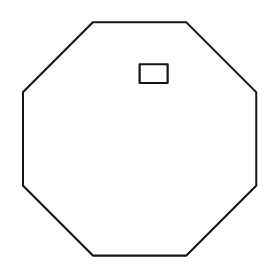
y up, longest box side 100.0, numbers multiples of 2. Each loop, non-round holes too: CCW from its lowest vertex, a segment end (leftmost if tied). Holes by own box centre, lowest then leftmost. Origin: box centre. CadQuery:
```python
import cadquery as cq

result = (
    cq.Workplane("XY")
    .moveTo(-20.0, -50.0)
    .lineTo(20.0, -50.0)
    .lineTo(50.0, -20.0)
    .lineTo(50.0, 20.0)
    .lineTo(20.0, 50.0)
    .lineTo(-20.0, 50.0)
    .lineTo(-50.0, 20.0)
    .lineTo(-50.0, -20.0)
    .close()
    .moveTo(0.0, 24.0)
    .lineTo(12.0, 24.0)
    .lineTo(12.0, 32.0)
    .lineTo(0.0, 32.0)
    .close()
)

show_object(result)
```